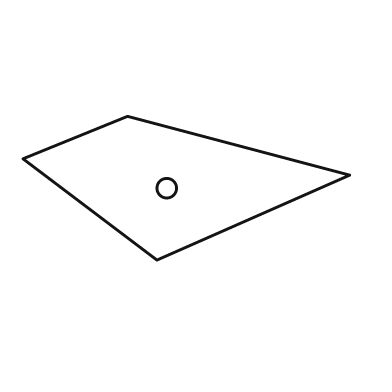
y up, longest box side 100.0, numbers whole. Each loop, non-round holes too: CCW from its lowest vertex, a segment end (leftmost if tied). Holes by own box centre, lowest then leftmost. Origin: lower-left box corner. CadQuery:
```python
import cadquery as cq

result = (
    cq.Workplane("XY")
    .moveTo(41.0, 0.0)
    .lineTo(100.0, 26.0)
    .lineTo(32.0, 44.0)
    .lineTo(0.0, 31.0)
    .close()
    .moveTo(44.0, 22.0)
    .circle(3.0)
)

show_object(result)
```